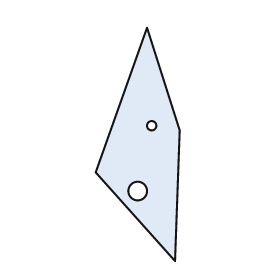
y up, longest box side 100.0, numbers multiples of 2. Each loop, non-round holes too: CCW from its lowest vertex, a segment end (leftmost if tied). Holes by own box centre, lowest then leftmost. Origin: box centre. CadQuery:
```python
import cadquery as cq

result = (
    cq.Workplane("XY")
    .moveTo(16.0, -50.0)
    .lineTo(18.0, 6.0)
    .lineTo(4.0, 50.0)
    .lineTo(-18.0, -12.0)
    .close()
    .moveTo(0.0, -20.0)
    .circle(4.0)
    .moveTo(6.0, 8.0)
    .circle(2.0)
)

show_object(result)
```